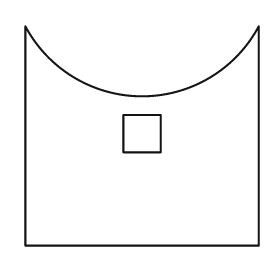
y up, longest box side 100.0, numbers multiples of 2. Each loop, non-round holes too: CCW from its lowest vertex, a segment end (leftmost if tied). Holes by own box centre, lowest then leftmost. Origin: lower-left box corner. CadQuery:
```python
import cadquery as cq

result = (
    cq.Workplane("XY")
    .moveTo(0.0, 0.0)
    .lineTo(100.0, 0.0)
    .lineTo(100.0, 94.0)
    .threePointArc((50.0, 64.0), (0.0, 94.0))
    .close()
    .moveTo(42.0, 40.0)
    .lineTo(58.0, 40.0)
    .lineTo(58.0, 56.0)
    .lineTo(42.0, 56.0)
    .close()
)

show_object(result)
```